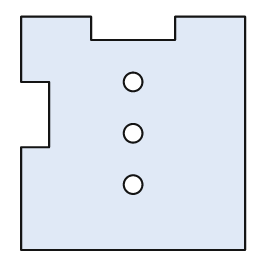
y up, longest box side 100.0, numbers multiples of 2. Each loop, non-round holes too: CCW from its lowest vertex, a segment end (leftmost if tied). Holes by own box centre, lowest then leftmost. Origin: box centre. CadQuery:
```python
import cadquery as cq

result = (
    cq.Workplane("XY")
    .moveTo(-48.0, -50.0)
    .lineTo(48.0, -50.0)
    .lineTo(48.0, 50.0)
    .lineTo(18.0, 50.0)
    .lineTo(18.0, 40.0)
    .lineTo(-18.0, 40.0)
    .lineTo(-18.0, 50.0)
    .lineTo(-48.0, 50.0)
    .lineTo(-48.0, 22.0)
    .lineTo(-36.0, 22.0)
    .lineTo(-36.0, -6.0)
    .lineTo(-48.0, -6.0)
    .close()
    .moveTo(0.0, -22.0)
    .circle(4.0)
    .moveTo(0.0, 0.0)
    .circle(4.0)
    .moveTo(0.0, 22.0)
    .circle(4.0)
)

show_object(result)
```